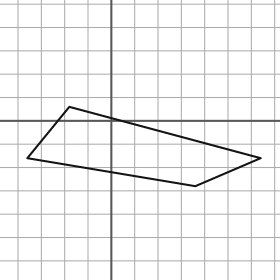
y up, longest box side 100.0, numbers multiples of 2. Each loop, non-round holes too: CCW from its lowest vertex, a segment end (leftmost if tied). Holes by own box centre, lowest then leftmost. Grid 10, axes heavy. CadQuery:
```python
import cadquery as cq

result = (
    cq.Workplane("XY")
    .moveTo(36.0, -28.0)
    .lineTo(64.0, -16.0)
    .lineTo(-18.0, 6.0)
    .lineTo(-36.0, -16.0)
    .close()
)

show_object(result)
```